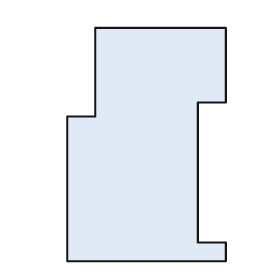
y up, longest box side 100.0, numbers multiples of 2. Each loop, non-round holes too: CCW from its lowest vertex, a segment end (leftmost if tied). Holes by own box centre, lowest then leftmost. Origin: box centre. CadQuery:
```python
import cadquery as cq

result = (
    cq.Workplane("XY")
    .moveTo(-34.0, -50.0)
    .lineTo(34.0, -50.0)
    .lineTo(34.0, -42.0)
    .lineTo(22.0, -42.0)
    .lineTo(22.0, 18.0)
    .lineTo(34.0, 18.0)
    .lineTo(34.0, 50.0)
    .lineTo(-22.0, 50.0)
    .lineTo(-22.0, 12.0)
    .lineTo(-34.0, 12.0)
    .close()
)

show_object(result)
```